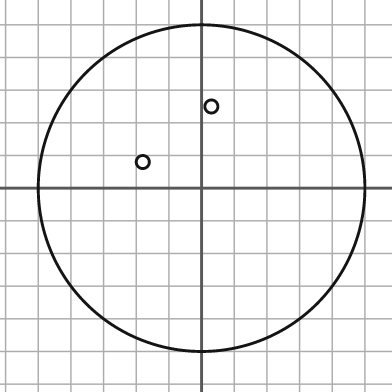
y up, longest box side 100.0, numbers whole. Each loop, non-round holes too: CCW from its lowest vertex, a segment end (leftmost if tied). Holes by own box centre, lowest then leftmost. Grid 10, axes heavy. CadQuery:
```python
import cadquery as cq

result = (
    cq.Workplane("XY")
    .moveTo(0.0, 0.0)
    .circle(50.0)
    .moveTo(-18.0, 8.0)
    .circle(2.0)
    .moveTo(3.0, 25.0)
    .circle(2.0)
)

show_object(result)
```